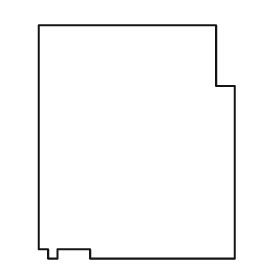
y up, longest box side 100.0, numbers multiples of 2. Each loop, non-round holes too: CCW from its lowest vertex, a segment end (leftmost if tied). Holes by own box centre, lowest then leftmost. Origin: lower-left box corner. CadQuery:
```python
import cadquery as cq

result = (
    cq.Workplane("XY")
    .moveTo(4.0, 0.0)
    .lineTo(8.0, 0.0)
    .lineTo(8.0, 4.0)
    .lineTo(22.0, 4.0)
    .lineTo(22.0, 0.0)
    .lineTo(84.0, 0.0)
    .lineTo(84.0, 74.0)
    .lineTo(76.0, 74.0)
    .lineTo(76.0, 100.0)
    .lineTo(0.0, 100.0)
    .lineTo(0.0, 4.0)
    .lineTo(4.0, 4.0)
    .close()
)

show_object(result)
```